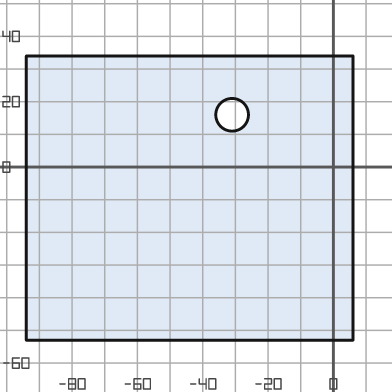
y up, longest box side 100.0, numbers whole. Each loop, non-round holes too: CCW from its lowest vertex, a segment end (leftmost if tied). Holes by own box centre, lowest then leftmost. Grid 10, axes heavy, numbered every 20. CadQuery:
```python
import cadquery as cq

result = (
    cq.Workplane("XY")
    .moveTo(-94.0, -53.0)
    .lineTo(6.0, -53.0)
    .lineTo(6.0, 34.0)
    .lineTo(-94.0, 34.0)
    .close()
    .moveTo(-31.0, 16.0)
    .circle(5.0)
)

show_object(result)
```